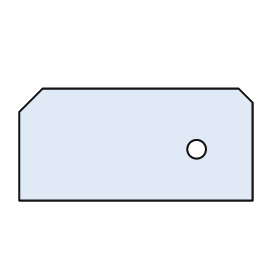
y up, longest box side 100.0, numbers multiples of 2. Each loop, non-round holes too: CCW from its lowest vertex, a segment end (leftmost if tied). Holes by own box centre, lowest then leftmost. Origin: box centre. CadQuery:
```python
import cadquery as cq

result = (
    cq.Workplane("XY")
    .moveTo(-50.0, -24.0)
    .lineTo(50.0, -24.0)
    .lineTo(50.0, 18.0)
    .lineTo(44.0, 24.0)
    .lineTo(-40.0, 24.0)
    .lineTo(-50.0, 14.0)
    .close()
    .moveTo(26.0, -2.0)
    .circle(4.0)
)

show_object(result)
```